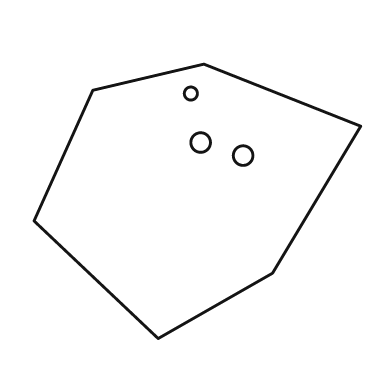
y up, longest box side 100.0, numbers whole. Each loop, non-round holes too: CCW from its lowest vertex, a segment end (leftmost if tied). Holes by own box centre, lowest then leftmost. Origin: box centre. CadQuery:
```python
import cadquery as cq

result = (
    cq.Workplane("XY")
    .moveTo(-12.0, -42.0)
    .lineTo(23.0, -22.0)
    .lineTo(50.0, 23.0)
    .lineTo(2.0, 42.0)
    .lineTo(-32.0, 34.0)
    .lineTo(-50.0, -6.0)
    .close()
    .moveTo(14.0, 14.0)
    .circle(3.0)
    .moveTo(1.0, 18.0)
    .circle(3.0)
    .moveTo(-2.0, 33.0)
    .circle(2.0)
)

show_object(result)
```